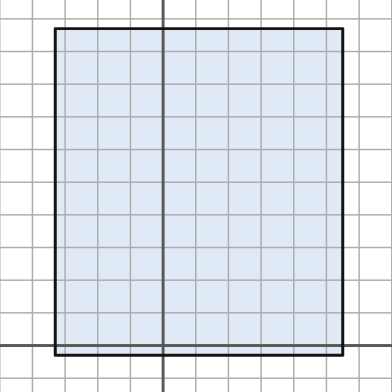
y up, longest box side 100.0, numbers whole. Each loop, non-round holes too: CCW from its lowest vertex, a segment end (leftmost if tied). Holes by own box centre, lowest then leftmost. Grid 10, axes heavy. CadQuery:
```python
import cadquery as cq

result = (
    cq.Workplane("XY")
    .moveTo(-33.0, -3.0)
    .lineTo(55.0, -3.0)
    .lineTo(55.0, 97.0)
    .lineTo(-33.0, 97.0)
    .close()
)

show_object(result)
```